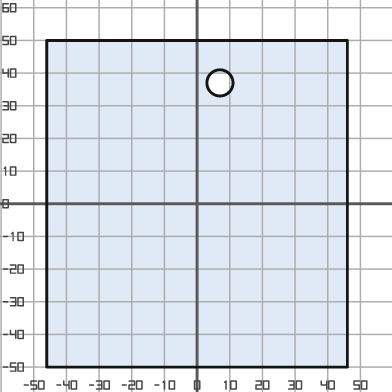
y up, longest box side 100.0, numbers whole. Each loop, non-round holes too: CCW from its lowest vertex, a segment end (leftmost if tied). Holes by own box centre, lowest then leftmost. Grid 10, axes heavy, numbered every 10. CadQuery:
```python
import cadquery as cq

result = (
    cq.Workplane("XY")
    .moveTo(-46.0, -50.0)
    .lineTo(46.0, -50.0)
    .lineTo(46.0, 50.0)
    .lineTo(-46.0, 50.0)
    .close()
    .moveTo(7.0, 37.0)
    .circle(4.0)
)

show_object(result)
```